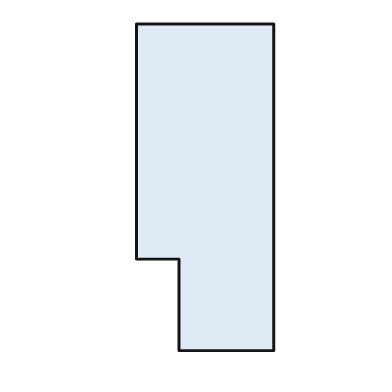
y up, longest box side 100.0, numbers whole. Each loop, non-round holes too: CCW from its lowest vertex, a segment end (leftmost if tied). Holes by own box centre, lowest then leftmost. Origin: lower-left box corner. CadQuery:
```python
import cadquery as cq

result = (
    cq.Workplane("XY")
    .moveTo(13.0, 0.0)
    .lineTo(42.0, 0.0)
    .lineTo(42.0, 100.0)
    .lineTo(0.0, 100.0)
    .lineTo(0.0, 28.0)
    .lineTo(13.0, 28.0)
    .close()
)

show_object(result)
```